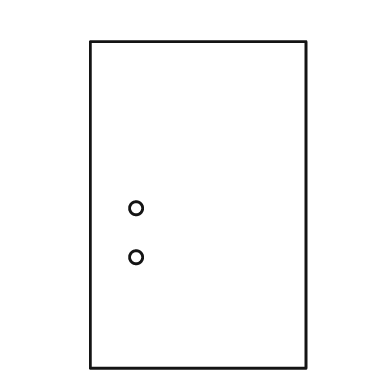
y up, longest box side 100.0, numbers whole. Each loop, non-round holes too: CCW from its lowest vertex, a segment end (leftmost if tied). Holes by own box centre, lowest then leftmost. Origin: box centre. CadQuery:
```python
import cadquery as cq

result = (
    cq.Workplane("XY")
    .moveTo(-33.0, -50.0)
    .lineTo(33.0, -50.0)
    .lineTo(33.0, 50.0)
    .lineTo(-33.0, 50.0)
    .close()
    .moveTo(-19.0, -16.0)
    .circle(2.0)
    .moveTo(-19.0, -1.0)
    .circle(2.0)
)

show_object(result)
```